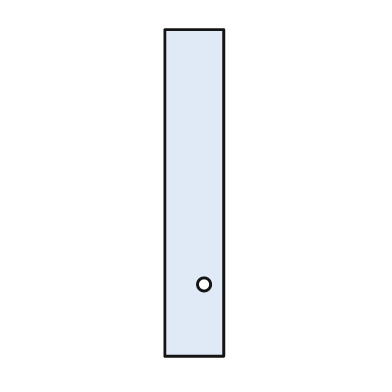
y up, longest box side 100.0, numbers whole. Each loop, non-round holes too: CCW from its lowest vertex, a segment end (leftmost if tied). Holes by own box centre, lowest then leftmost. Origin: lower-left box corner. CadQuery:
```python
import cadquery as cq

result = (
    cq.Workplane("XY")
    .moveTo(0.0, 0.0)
    .lineTo(18.0, 0.0)
    .lineTo(18.0, 100.0)
    .lineTo(0.0, 100.0)
    .close()
    .moveTo(12.0, 22.0)
    .circle(2.0)
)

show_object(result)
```